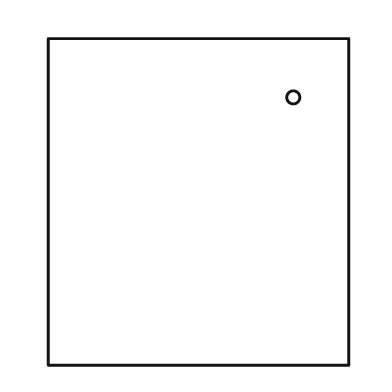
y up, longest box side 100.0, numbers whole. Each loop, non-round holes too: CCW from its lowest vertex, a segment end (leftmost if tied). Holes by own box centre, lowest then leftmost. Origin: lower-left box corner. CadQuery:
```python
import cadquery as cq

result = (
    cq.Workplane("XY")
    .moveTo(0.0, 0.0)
    .lineTo(92.0, 0.0)
    .lineTo(92.0, 100.0)
    .lineTo(0.0, 100.0)
    .close()
    .moveTo(75.0, 82.0)
    .circle(2.0)
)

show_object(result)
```